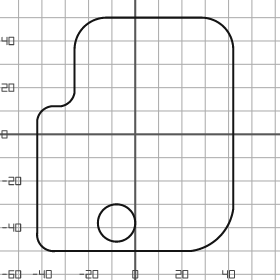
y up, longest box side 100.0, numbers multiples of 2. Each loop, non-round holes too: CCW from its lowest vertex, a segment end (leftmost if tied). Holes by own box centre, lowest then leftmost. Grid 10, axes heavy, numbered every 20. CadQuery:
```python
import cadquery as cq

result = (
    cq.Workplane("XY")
    .moveTo(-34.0, -50.0)
    .lineTo(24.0, -50.0)
    .threePointArc((36.0, -44.0), (42.0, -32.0))
    .lineTo(42.0, 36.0)
    .threePointArc((38.0, 46.0), (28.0, 50.0))
    .lineTo(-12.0, 50.0)
    .threePointArc((-22.0, 46.0), (-26.0, 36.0))
    .lineTo(-26.0, 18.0)
    .threePointArc((-28.0, 14.0), (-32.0, 12.0))
    .lineTo(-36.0, 12.0)
    .threePointArc((-40.0, 10.0), (-42.0, 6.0))
    .lineTo(-42.0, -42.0)
    .threePointArc((-40.0, -48.0), (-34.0, -50.0))
    .close()
    .moveTo(-8.0, -38.0)
    .circle(8.0)
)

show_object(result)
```